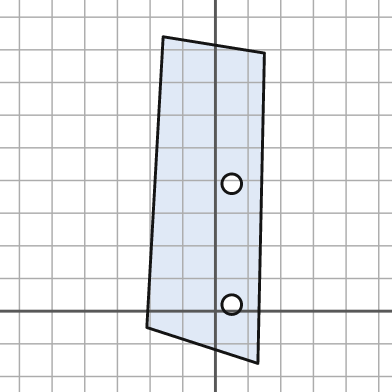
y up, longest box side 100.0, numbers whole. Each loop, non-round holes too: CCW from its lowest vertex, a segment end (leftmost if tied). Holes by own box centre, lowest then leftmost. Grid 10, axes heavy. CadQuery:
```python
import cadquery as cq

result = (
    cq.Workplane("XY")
    .moveTo(13.0, -16.0)
    .lineTo(15.0, 79.0)
    .lineTo(-16.0, 84.0)
    .lineTo(-21.0, -5.0)
    .close()
    .moveTo(5.0, 2.0)
    .circle(3.0)
    .moveTo(5.0, 39.0)
    .circle(3.0)
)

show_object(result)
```